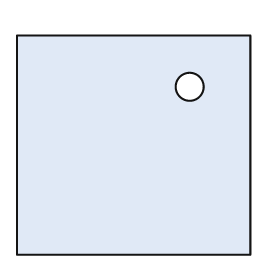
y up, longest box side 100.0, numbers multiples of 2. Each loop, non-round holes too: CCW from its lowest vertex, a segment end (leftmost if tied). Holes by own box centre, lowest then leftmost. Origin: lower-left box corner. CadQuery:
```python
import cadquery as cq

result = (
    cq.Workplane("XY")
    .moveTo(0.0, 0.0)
    .lineTo(100.0, 0.0)
    .lineTo(100.0, 94.0)
    .lineTo(0.0, 94.0)
    .close()
    .moveTo(74.0, 72.0)
    .circle(6.0)
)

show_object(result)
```